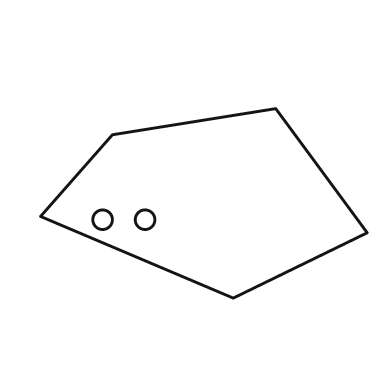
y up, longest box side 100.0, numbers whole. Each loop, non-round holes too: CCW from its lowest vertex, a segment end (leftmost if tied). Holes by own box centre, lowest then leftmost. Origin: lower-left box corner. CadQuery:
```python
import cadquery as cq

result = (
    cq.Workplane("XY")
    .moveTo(59.0, 0.0)
    .lineTo(100.0, 20.0)
    .lineTo(72.0, 58.0)
    .lineTo(22.0, 50.0)
    .lineTo(0.0, 25.0)
    .close()
    .moveTo(19.0, 24.0)
    .circle(3.0)
    .moveTo(32.0, 24.0)
    .circle(3.0)
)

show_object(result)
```